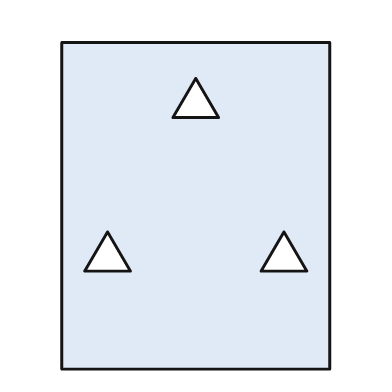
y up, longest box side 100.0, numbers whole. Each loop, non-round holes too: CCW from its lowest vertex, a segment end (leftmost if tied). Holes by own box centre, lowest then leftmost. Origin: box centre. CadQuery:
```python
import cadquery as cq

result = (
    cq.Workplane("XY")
    .moveTo(-41.0, -50.0)
    .lineTo(41.0, -50.0)
    .lineTo(41.0, 50.0)
    .lineTo(-41.0, 50.0)
    .close()
    .moveTo(-34.0, -20.0)
    .lineTo(-20.0, -20.0)
    .lineTo(-27.0, -8.0)
    .close()
    .moveTo(20.0, -20.0)
    .lineTo(34.0, -20.0)
    .lineTo(27.0, -8.0)
    .close()
    .moveTo(-7.0, 27.0)
    .lineTo(7.0, 27.0)
    .lineTo(0.0, 39.0)
    .close()
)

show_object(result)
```